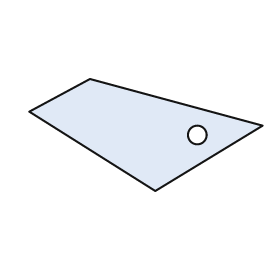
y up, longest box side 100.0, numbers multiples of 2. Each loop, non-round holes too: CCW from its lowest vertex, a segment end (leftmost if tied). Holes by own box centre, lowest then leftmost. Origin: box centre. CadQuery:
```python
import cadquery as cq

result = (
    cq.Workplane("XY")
    .moveTo(4.0, -24.0)
    .lineTo(50.0, 4.0)
    .lineTo(-24.0, 24.0)
    .lineTo(-50.0, 10.0)
    .close()
    .moveTo(22.0, 0.0)
    .circle(4.0)
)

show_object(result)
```